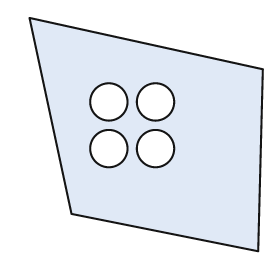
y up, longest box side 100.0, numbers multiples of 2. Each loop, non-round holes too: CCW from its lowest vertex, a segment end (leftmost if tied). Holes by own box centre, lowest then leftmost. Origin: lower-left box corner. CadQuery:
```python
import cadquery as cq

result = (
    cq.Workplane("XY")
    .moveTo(98.0, 0.0)
    .lineTo(100.0, 78.0)
    .lineTo(0.0, 100.0)
    .lineTo(18.0, 16.0)
    .close()
    .moveTo(34.0, 44.0)
    .circle(8.0)
    .moveTo(54.0, 44.0)
    .circle(8.0)
    .moveTo(34.0, 64.0)
    .circle(8.0)
    .moveTo(54.0, 64.0)
    .circle(8.0)
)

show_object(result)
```